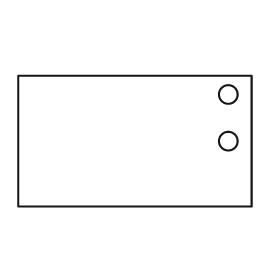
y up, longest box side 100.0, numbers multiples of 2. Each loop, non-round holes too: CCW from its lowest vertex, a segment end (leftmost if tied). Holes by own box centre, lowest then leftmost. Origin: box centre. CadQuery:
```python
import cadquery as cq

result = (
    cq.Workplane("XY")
    .moveTo(-50.0, -28.0)
    .lineTo(50.0, -28.0)
    .lineTo(50.0, 28.0)
    .lineTo(-50.0, 28.0)
    .close()
    .moveTo(40.0, 0.0)
    .circle(4.0)
    .moveTo(40.0, 20.0)
    .circle(4.0)
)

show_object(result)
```